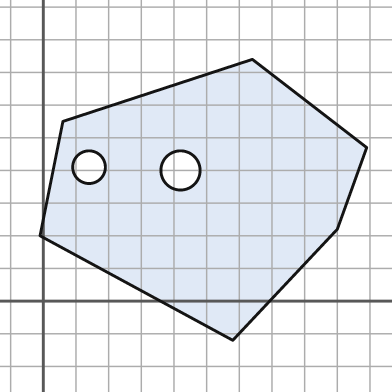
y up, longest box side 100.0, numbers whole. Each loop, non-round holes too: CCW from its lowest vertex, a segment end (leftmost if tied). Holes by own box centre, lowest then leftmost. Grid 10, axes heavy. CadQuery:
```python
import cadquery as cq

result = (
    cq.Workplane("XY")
    .moveTo(58.0, -12.0)
    .lineTo(90.0, 22.0)
    .lineTo(99.0, 47.0)
    .lineTo(64.0, 74.0)
    .lineTo(6.0, 55.0)
    .lineTo(-1.0, 20.0)
    .close()
    .moveTo(42.0, 40.0)
    .circle(6.0)
    .moveTo(14.0, 41.0)
    .circle(5.0)
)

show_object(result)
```